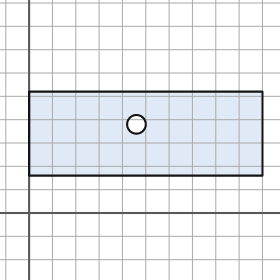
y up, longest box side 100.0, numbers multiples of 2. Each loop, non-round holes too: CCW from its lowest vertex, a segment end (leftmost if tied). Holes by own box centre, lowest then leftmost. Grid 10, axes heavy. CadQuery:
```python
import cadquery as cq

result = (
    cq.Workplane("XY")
    .moveTo(0.0, 16.0)
    .lineTo(100.0, 16.0)
    .lineTo(100.0, 52.0)
    .lineTo(0.0, 52.0)
    .close()
    .moveTo(46.0, 38.0)
    .circle(4.0)
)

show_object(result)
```